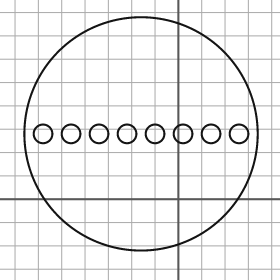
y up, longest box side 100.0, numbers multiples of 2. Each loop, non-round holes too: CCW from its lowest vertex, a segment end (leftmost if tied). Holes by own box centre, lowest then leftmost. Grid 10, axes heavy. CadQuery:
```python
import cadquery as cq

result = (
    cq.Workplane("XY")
    .moveTo(-16.0, 28.0)
    .circle(50.0)
    .moveTo(-58.0, 28.0)
    .circle(4.0)
    .moveTo(-46.0, 28.0)
    .circle(4.0)
    .moveTo(-34.0, 28.0)
    .circle(4.0)
    .moveTo(-22.0, 28.0)
    .circle(4.0)
    .moveTo(-10.0, 28.0)
    .circle(4.0)
    .moveTo(2.0, 28.0)
    .circle(4.0)
    .moveTo(14.0, 28.0)
    .circle(4.0)
    .moveTo(26.0, 28.0)
    .circle(4.0)
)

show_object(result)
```